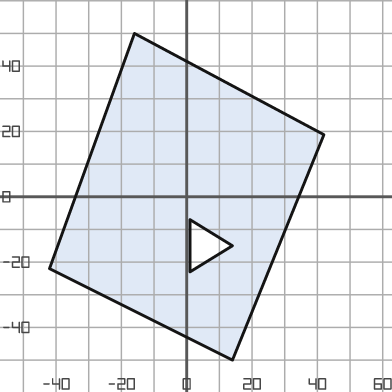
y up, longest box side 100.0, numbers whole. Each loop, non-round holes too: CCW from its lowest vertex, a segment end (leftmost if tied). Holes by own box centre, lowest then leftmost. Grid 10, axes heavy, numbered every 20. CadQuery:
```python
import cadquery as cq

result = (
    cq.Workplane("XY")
    .moveTo(14.0, -50.0)
    .lineTo(42.0, 19.0)
    .lineTo(-16.0, 50.0)
    .lineTo(-42.0, -22.0)
    .close()
    .moveTo(1.0, -23.0)
    .lineTo(14.0, -15.0)
    .lineTo(1.0, -7.0)
    .close()
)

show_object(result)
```